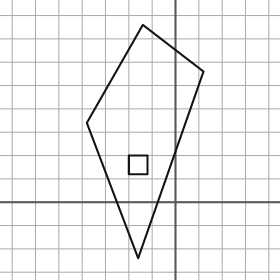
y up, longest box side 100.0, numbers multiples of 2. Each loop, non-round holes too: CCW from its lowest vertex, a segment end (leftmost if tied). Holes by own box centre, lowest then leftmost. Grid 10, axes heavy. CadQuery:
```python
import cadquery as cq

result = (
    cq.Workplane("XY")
    .moveTo(-16.0, -24.0)
    .lineTo(12.0, 56.0)
    .lineTo(-14.0, 76.0)
    .lineTo(-38.0, 34.0)
    .close()
    .moveTo(-20.0, 12.0)
    .lineTo(-12.0, 12.0)
    .lineTo(-12.0, 20.0)
    .lineTo(-20.0, 20.0)
    .close()
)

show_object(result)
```